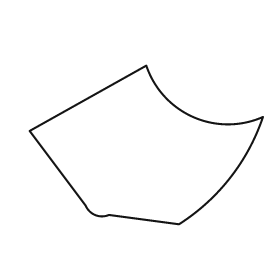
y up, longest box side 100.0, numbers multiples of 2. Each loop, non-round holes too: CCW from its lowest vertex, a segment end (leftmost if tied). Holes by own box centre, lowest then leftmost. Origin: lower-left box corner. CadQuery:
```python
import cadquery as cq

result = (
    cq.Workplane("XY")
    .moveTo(64.0, 0.0)
    .threePointArc((86.0, 20.0), (100.0, 46.0))
    .threePointArc((70.0, 46.0), (50.0, 68.0))
    .lineTo(0.0, 40.0)
    .lineTo(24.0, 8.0)
    .threePointArc((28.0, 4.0), (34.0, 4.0))
    .close()
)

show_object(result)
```